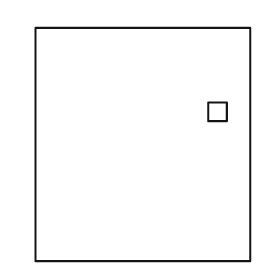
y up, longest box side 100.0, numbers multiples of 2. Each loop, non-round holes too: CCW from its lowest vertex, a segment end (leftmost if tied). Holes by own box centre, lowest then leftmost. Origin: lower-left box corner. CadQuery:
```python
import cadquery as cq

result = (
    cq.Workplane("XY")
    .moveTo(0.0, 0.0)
    .lineTo(92.0, 0.0)
    .lineTo(92.0, 100.0)
    .lineTo(0.0, 100.0)
    .close()
    .moveTo(74.0, 60.0)
    .lineTo(82.0, 60.0)
    .lineTo(82.0, 68.0)
    .lineTo(74.0, 68.0)
    .close()
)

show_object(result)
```